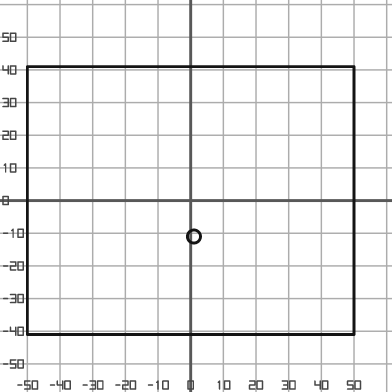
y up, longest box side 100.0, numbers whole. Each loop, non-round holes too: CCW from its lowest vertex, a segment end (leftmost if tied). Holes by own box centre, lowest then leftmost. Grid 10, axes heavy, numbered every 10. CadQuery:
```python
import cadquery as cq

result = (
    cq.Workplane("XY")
    .moveTo(-50.0, -41.0)
    .lineTo(50.0, -41.0)
    .lineTo(50.0, 41.0)
    .lineTo(-50.0, 41.0)
    .close()
    .moveTo(1.0, -11.0)
    .circle(2.0)
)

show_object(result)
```